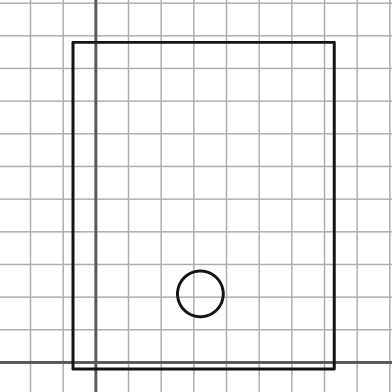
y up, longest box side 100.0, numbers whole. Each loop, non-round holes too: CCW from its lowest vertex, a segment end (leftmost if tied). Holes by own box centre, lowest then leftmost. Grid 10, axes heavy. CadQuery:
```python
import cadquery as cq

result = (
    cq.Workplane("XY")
    .moveTo(-7.0, -2.0)
    .lineTo(73.0, -2.0)
    .lineTo(73.0, 98.0)
    .lineTo(-7.0, 98.0)
    .close()
    .moveTo(32.0, 21.0)
    .circle(7.0)
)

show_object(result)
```